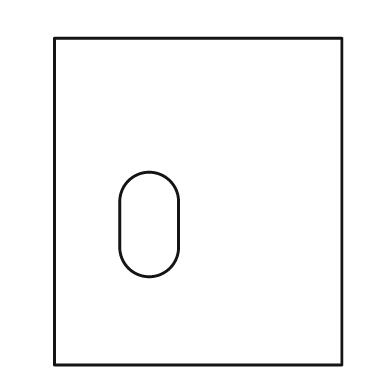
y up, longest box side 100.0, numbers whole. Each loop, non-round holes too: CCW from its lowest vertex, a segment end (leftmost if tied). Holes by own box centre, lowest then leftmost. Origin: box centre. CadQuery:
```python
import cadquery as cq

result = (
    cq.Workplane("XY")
    .moveTo(-44.0, -50.0)
    .lineTo(44.0, -50.0)
    .lineTo(44.0, 50.0)
    .lineTo(-44.0, 50.0)
    .close()
    .moveTo(-24.0, -14.0)
    .threePointArc((-15.0, -23.0), (-6.0, -14.0))
    .lineTo(-6.0, 0.0)
    .threePointArc((-15.0, 9.0), (-24.0, 0.0))
    .close()
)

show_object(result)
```